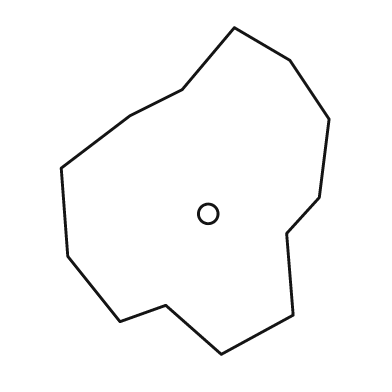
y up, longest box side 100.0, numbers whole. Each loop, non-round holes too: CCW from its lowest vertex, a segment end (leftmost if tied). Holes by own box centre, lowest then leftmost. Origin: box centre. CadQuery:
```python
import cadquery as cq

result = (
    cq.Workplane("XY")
    .moveTo(8.0, -50.0)
    .lineTo(30.0, -38.0)
    .lineTo(28.0, -13.0)
    .lineTo(38.0, -2.0)
    .lineTo(41.0, 22.0)
    .lineTo(29.0, 40.0)
    .lineTo(12.0, 50.0)
    .lineTo(-4.0, 31.0)
    .lineTo(-20.0, 23.0)
    .lineTo(-41.0, 7.0)
    .lineTo(-39.0, -20.0)
    .lineTo(-23.0, -40.0)
    .lineTo(-9.0, -35.0)
    .close()
    .moveTo(4.0, -7.0)
    .circle(3.0)
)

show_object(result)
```